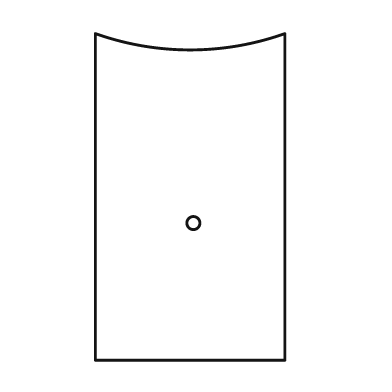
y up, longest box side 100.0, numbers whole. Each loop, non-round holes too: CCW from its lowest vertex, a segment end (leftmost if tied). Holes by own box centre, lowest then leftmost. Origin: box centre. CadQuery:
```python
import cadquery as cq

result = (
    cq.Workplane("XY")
    .moveTo(-29.0, -50.0)
    .lineTo(29.0, -50.0)
    .lineTo(29.0, 50.0)
    .threePointArc((0.0, 45.0), (-29.0, 50.0))
    .close()
    .moveTo(1.0, -8.0)
    .circle(2.0)
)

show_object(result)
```